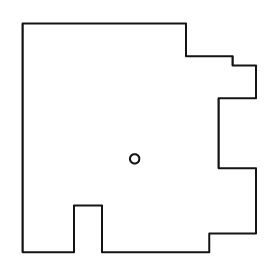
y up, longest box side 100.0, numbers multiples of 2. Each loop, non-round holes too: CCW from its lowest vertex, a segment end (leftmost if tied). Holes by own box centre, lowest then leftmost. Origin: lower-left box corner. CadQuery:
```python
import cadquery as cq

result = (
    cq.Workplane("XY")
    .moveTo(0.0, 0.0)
    .lineTo(22.0, 0.0)
    .lineTo(22.0, 20.0)
    .lineTo(34.0, 20.0)
    .lineTo(34.0, 0.0)
    .lineTo(80.0, 0.0)
    .lineTo(80.0, 8.0)
    .lineTo(100.0, 8.0)
    .lineTo(100.0, 36.0)
    .lineTo(84.0, 36.0)
    .lineTo(84.0, 66.0)
    .lineTo(100.0, 66.0)
    .lineTo(100.0, 80.0)
    .lineTo(90.0, 80.0)
    .lineTo(90.0, 84.0)
    .lineTo(70.0, 84.0)
    .lineTo(70.0, 98.0)
    .lineTo(0.0, 98.0)
    .close()
    .moveTo(48.0, 40.0)
    .circle(2.0)
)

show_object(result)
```